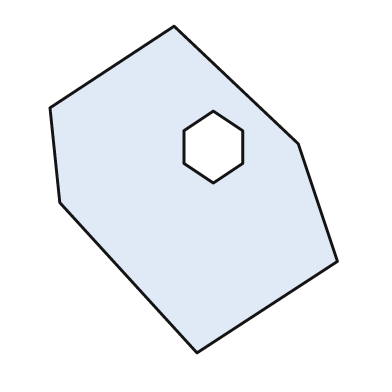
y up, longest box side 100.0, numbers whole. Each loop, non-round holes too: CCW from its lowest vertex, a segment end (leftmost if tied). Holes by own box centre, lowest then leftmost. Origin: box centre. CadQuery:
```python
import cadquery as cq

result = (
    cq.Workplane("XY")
    .moveTo(1.0, -50.0)
    .lineTo(44.0, -22.0)
    .lineTo(32.0, 14.0)
    .lineTo(-6.0, 50.0)
    .lineTo(-44.0, 25.0)
    .lineTo(-41.0, -4.0)
    .close()
    .moveTo(6.0, 2.0)
    .lineTo(15.0, 8.0)
    .lineTo(15.0, 18.0)
    .lineTo(6.0, 24.0)
    .lineTo(-3.0, 18.0)
    .lineTo(-3.0, 8.0)
    .close()
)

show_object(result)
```